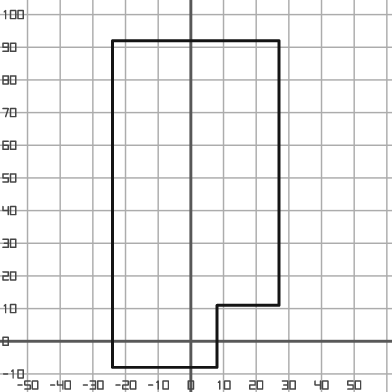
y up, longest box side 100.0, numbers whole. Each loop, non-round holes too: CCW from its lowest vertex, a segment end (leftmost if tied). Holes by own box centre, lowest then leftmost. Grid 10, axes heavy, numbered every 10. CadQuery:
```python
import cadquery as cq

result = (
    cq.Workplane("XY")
    .moveTo(-24.0, -8.0)
    .lineTo(8.0, -8.0)
    .lineTo(8.0, 11.0)
    .lineTo(27.0, 11.0)
    .lineTo(27.0, 92.0)
    .lineTo(-24.0, 92.0)
    .close()
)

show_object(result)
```